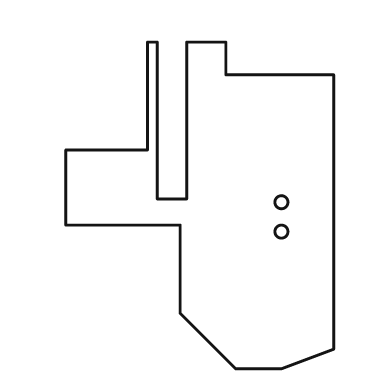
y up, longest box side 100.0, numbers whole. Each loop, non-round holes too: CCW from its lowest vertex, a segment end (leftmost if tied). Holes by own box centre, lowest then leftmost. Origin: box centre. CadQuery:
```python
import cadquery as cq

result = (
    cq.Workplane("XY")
    .moveTo(11.0, -50.0)
    .lineTo(25.0, -50.0)
    .lineTo(41.0, -44.0)
    .lineTo(41.0, 40.0)
    .lineTo(8.0, 40.0)
    .lineTo(8.0, 50.0)
    .lineTo(-4.0, 50.0)
    .lineTo(-4.0, 2.0)
    .lineTo(-13.0, 2.0)
    .lineTo(-13.0, 50.0)
    .lineTo(-16.0, 50.0)
    .lineTo(-16.0, 17.0)
    .lineTo(-41.0, 17.0)
    .lineTo(-41.0, -6.0)
    .lineTo(-6.0, -6.0)
    .lineTo(-6.0, -33.0)
    .close()
    .moveTo(25.0, -8.0)
    .circle(2.0)
    .moveTo(25.0, 1.0)
    .circle(2.0)
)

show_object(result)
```